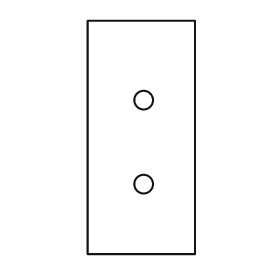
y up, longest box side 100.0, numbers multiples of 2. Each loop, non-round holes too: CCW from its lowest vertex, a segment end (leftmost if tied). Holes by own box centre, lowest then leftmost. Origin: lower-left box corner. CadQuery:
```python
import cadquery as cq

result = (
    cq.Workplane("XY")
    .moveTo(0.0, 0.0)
    .lineTo(46.0, 0.0)
    .lineTo(46.0, 100.0)
    .lineTo(0.0, 100.0)
    .close()
    .moveTo(24.0, 30.0)
    .circle(4.0)
    .moveTo(24.0, 66.0)
    .circle(4.0)
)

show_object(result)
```